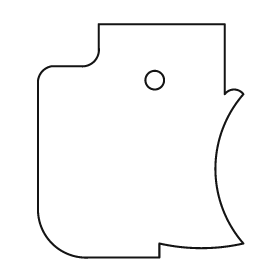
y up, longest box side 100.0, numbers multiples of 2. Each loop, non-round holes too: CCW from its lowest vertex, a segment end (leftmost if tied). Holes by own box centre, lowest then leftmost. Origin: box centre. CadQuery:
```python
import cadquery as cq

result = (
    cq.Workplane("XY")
    .moveTo(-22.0, -50.0)
    .lineTo(8.0, -50.0)
    .lineTo(8.0, -44.0)
    .threePointArc((26.0, -46.0), (44.0, -44.0))
    .threePointArc((32.0, -12.0), (44.0, 20.0))
    .threePointArc((40.0, 22.0), (36.0, 20.0))
    .lineTo(36.0, 50.0)
    .lineTo(-18.0, 50.0)
    .lineTo(-18.0, 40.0)
    .threePointArc((-20.0, 34.0), (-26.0, 32.0))
    .lineTo(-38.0, 32.0)
    .threePointArc((-42.0, 30.0), (-44.0, 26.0))
    .lineTo(-44.0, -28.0)
    .threePointArc((-38.0, -44.0), (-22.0, -50.0))
    .close()
    .moveTo(6.0, 26.0)
    .circle(4.0)
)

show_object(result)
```